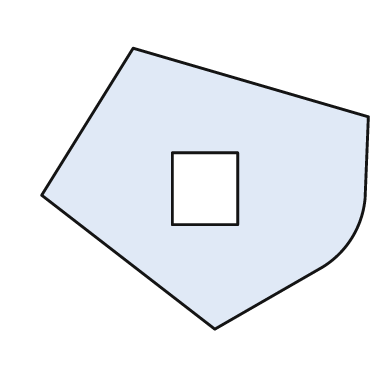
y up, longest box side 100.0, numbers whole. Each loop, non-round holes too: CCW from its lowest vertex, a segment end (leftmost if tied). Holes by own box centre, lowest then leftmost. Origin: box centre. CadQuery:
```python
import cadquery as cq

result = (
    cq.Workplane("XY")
    .moveTo(3.0, -43.0)
    .lineTo(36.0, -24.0)
    .threePointArc((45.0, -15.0), (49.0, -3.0))
    .lineTo(50.0, 22.0)
    .lineTo(-22.0, 43.0)
    .lineTo(-50.0, -2.0)
    .close()
    .moveTo(-10.0, -11.0)
    .lineTo(10.0, -11.0)
    .lineTo(10.0, 11.0)
    .lineTo(-10.0, 11.0)
    .close()
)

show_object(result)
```